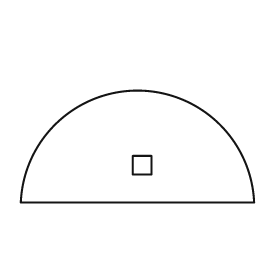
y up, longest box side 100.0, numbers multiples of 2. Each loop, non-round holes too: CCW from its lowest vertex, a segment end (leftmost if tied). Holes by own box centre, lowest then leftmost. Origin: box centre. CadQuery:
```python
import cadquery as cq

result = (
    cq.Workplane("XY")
    .moveTo(-50.0, -24.0)
    .lineTo(50.0, -24.0)
    .threePointArc((0.0, 24.0), (-50.0, -24.0))
    .close()
    .moveTo(-2.0, -12.0)
    .lineTo(6.0, -12.0)
    .lineTo(6.0, -4.0)
    .lineTo(-2.0, -4.0)
    .close()
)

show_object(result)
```